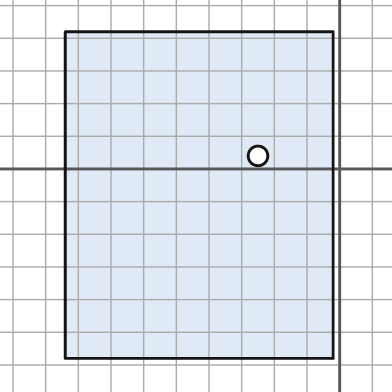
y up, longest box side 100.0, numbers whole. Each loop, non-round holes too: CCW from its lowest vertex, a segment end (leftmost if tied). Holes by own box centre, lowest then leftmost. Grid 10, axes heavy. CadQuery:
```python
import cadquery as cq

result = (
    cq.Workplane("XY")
    .moveTo(-84.0, -58.0)
    .lineTo(-2.0, -58.0)
    .lineTo(-2.0, 42.0)
    .lineTo(-84.0, 42.0)
    .close()
    .moveTo(-25.0, 4.0)
    .circle(3.0)
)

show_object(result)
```